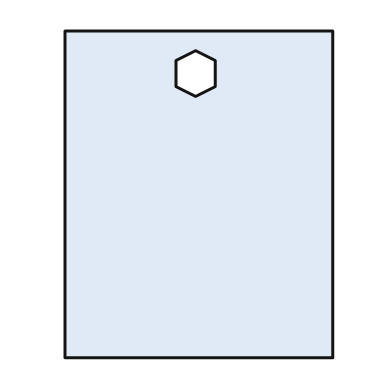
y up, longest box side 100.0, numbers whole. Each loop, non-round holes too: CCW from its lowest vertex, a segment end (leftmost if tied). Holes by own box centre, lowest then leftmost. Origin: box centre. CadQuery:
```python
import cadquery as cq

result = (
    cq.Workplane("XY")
    .moveTo(-41.0, -50.0)
    .lineTo(41.0, -50.0)
    .lineTo(41.0, 50.0)
    .lineTo(-41.0, 50.0)
    .close()
    .moveTo(-1.0, 30.0)
    .lineTo(5.0, 33.0)
    .lineTo(5.0, 41.0)
    .lineTo(-1.0, 44.0)
    .lineTo(-7.0, 41.0)
    .lineTo(-7.0, 33.0)
    .close()
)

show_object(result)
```